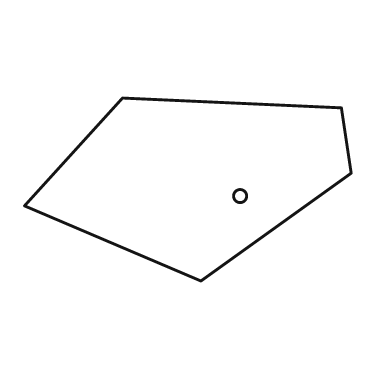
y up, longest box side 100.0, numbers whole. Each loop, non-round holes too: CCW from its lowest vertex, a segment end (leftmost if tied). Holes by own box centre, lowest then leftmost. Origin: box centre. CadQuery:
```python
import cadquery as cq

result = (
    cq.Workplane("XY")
    .moveTo(4.0, -28.0)
    .lineTo(50.0, 5.0)
    .lineTo(47.0, 25.0)
    .lineTo(-20.0, 28.0)
    .lineTo(-50.0, -5.0)
    .close()
    .moveTo(16.0, -2.0)
    .circle(2.0)
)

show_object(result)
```